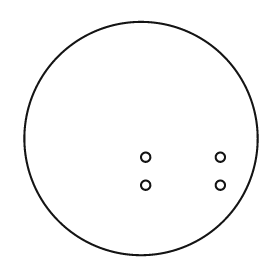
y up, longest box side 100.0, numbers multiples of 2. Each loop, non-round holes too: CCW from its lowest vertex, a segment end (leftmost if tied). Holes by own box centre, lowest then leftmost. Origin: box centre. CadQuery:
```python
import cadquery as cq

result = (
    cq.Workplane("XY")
    .moveTo(0.0, 0.0)
    .circle(50.0)
    .moveTo(2.0, -20.0)
    .circle(2.0)
    .moveTo(34.0, -20.0)
    .circle(2.0)
    .moveTo(2.0, -8.0)
    .circle(2.0)
    .moveTo(34.0, -8.0)
    .circle(2.0)
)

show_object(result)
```